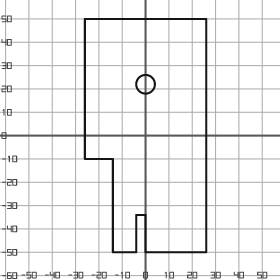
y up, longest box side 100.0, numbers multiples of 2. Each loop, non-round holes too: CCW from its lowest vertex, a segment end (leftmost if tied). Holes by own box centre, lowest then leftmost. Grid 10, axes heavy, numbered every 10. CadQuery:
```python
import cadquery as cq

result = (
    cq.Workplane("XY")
    .moveTo(-14.0, -50.0)
    .lineTo(-4.0, -50.0)
    .lineTo(-4.0, -34.0)
    .lineTo(0.0, -34.0)
    .lineTo(0.0, -50.0)
    .lineTo(26.0, -50.0)
    .lineTo(26.0, 50.0)
    .lineTo(-26.0, 50.0)
    .lineTo(-26.0, -10.0)
    .lineTo(-14.0, -10.0)
    .close()
    .moveTo(0.0, 22.0)
    .circle(4.0)
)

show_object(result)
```